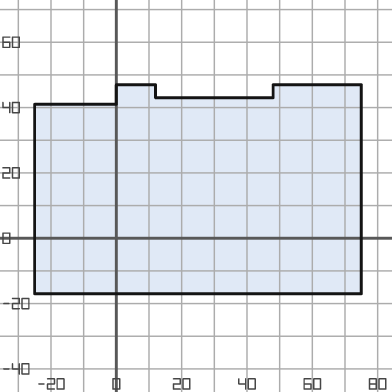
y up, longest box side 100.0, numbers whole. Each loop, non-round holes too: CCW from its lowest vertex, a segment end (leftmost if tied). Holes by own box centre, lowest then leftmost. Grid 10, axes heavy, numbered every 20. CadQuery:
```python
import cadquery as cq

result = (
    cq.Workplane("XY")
    .moveTo(-25.0, -17.0)
    .lineTo(75.0, -17.0)
    .lineTo(75.0, 47.0)
    .lineTo(48.0, 47.0)
    .lineTo(48.0, 43.0)
    .lineTo(12.0, 43.0)
    .lineTo(12.0, 47.0)
    .lineTo(0.0, 47.0)
    .lineTo(0.0, 41.0)
    .lineTo(-25.0, 41.0)
    .close()
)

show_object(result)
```